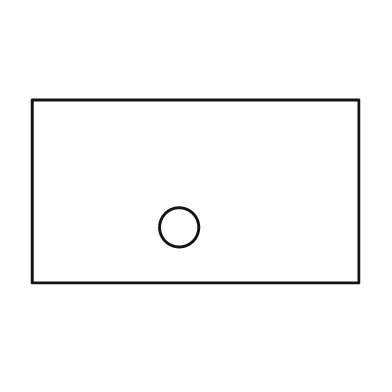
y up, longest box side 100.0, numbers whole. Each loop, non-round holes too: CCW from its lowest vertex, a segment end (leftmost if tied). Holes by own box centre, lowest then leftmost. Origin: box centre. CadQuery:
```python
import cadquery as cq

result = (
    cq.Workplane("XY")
    .moveTo(-50.0, -28.0)
    .lineTo(50.0, -28.0)
    .lineTo(50.0, 28.0)
    .lineTo(-50.0, 28.0)
    .close()
    .moveTo(-5.0, -11.0)
    .circle(6.0)
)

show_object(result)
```